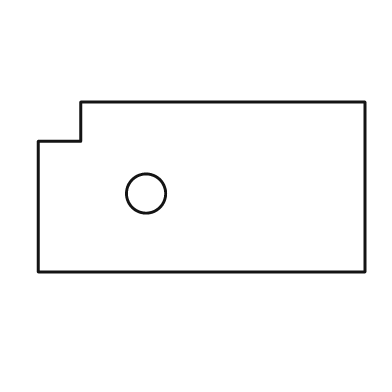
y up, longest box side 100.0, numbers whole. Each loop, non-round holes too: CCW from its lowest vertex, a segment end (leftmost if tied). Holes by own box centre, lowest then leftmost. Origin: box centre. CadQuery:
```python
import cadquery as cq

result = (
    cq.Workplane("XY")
    .moveTo(-50.0, -26.0)
    .lineTo(50.0, -26.0)
    .lineTo(50.0, 26.0)
    .lineTo(-37.0, 26.0)
    .lineTo(-37.0, 14.0)
    .lineTo(-50.0, 14.0)
    .close()
    .moveTo(-17.0, -2.0)
    .circle(6.0)
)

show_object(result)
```